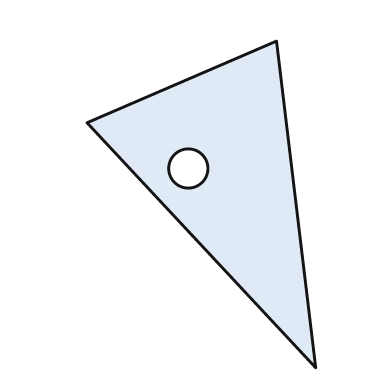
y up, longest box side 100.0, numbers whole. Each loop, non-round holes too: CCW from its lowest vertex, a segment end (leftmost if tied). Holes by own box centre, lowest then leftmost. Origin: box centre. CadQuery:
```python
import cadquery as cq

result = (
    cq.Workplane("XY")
    .moveTo(35.0, -50.0)
    .lineTo(23.0, 50.0)
    .lineTo(-35.0, 25.0)
    .close()
    .moveTo(-4.0, 11.0)
    .circle(6.0)
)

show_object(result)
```